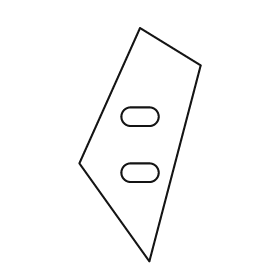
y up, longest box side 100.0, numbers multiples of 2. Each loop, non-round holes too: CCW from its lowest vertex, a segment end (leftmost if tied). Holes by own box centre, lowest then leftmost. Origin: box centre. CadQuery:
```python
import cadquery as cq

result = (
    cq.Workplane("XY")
    .moveTo(4.0, -50.0)
    .lineTo(26.0, 34.0)
    .lineTo(0.0, 50.0)
    .lineTo(-26.0, -8.0)
    .close()
    .moveTo(-4.0, -16.0)
    .lineTo(4.0, -16.0)
    .threePointArc((8.0, -12.0), (4.0, -8.0))
    .lineTo(-4.0, -8.0)
    .threePointArc((-8.0, -12.0), (-4.0, -16.0))
    .close()
    .moveTo(-4.0, 8.0)
    .lineTo(4.0, 8.0)
    .threePointArc((8.0, 12.0), (4.0, 16.0))
    .lineTo(-4.0, 16.0)
    .threePointArc((-8.0, 12.0), (-4.0, 8.0))
    .close()
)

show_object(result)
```